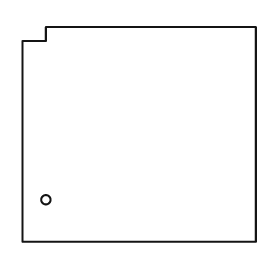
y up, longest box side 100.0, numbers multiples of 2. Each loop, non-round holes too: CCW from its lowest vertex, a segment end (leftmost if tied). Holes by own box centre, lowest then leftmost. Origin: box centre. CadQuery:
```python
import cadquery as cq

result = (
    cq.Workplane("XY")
    .moveTo(-50.0, -46.0)
    .lineTo(50.0, -46.0)
    .lineTo(50.0, 46.0)
    .lineTo(-40.0, 46.0)
    .lineTo(-40.0, 40.0)
    .lineTo(-50.0, 40.0)
    .close()
    .moveTo(-40.0, -28.0)
    .circle(2.0)
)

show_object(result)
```